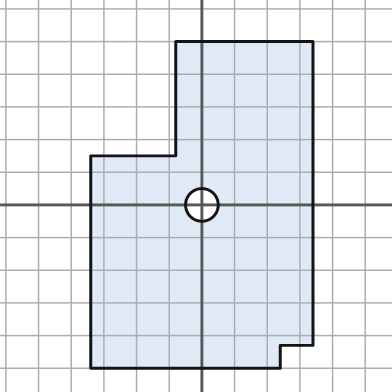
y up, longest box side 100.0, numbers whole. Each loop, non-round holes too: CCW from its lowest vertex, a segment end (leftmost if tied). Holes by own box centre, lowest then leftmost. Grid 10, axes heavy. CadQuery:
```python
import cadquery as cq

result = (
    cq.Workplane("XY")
    .moveTo(-34.0, -50.0)
    .lineTo(24.0, -50.0)
    .lineTo(24.0, -43.0)
    .lineTo(34.0, -43.0)
    .lineTo(34.0, 50.0)
    .lineTo(-8.0, 50.0)
    .lineTo(-8.0, 15.0)
    .lineTo(-34.0, 15.0)
    .close()
    .moveTo(0.0, 0.0)
    .circle(5.0)
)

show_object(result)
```